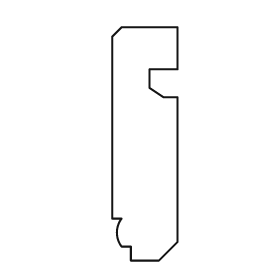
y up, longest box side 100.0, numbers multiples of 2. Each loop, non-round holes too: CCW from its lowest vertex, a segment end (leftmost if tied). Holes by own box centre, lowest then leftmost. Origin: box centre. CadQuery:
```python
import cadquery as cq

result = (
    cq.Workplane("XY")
    .moveTo(-6.0, -50.0)
    .lineTo(6.0, -50.0)
    .lineTo(14.0, -42.0)
    .lineTo(14.0, 20.0)
    .lineTo(8.0, 20.0)
    .lineTo(2.0, 24.0)
    .lineTo(2.0, 32.0)
    .lineTo(14.0, 32.0)
    .lineTo(14.0, 50.0)
    .lineTo(-10.0, 50.0)
    .lineTo(-14.0, 46.0)
    .lineTo(-14.0, -32.0)
    .lineTo(-10.0, -32.0)
    .threePointArc((-12.0, -38.0), (-10.0, -44.0))
    .lineTo(-6.0, -44.0)
    .close()
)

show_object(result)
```